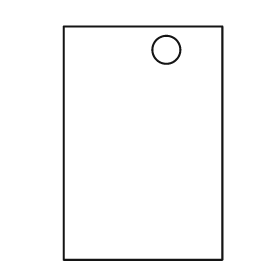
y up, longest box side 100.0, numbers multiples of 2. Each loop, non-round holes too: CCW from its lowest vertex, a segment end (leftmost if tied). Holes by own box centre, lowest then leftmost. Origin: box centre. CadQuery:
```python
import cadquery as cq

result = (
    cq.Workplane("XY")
    .moveTo(-34.0, -50.0)
    .lineTo(34.0, -50.0)
    .lineTo(34.0, 50.0)
    .lineTo(-34.0, 50.0)
    .close()
    .moveTo(10.0, 40.0)
    .circle(6.0)
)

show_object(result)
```